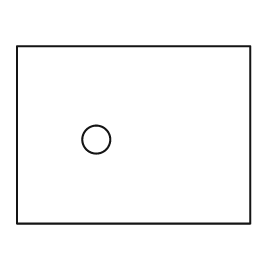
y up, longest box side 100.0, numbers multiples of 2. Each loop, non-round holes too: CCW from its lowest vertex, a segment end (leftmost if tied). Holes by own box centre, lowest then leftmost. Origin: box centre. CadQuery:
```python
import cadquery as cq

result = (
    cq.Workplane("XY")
    .moveTo(-50.0, -38.0)
    .lineTo(50.0, -38.0)
    .lineTo(50.0, 38.0)
    .lineTo(-50.0, 38.0)
    .close()
    .moveTo(-16.0, -2.0)
    .circle(6.0)
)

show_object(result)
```